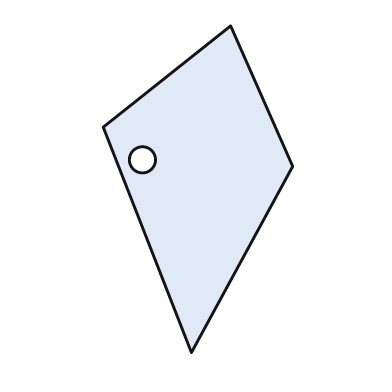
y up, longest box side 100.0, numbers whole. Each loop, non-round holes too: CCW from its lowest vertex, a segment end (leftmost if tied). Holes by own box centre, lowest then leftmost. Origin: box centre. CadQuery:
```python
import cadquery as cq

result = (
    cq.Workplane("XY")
    .moveTo(-2.0, -50.0)
    .lineTo(29.0, 7.0)
    .lineTo(10.0, 50.0)
    .lineTo(-29.0, 19.0)
    .close()
    .moveTo(-17.0, 9.0)
    .circle(4.0)
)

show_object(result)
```